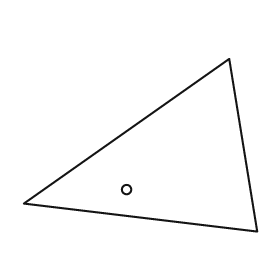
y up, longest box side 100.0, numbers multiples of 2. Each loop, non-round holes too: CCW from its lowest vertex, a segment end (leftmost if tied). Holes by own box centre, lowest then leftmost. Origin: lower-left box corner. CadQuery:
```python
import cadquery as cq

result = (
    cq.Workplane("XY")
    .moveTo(100.0, 0.0)
    .lineTo(88.0, 74.0)
    .lineTo(0.0, 12.0)
    .close()
    .moveTo(44.0, 18.0)
    .circle(2.0)
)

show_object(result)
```